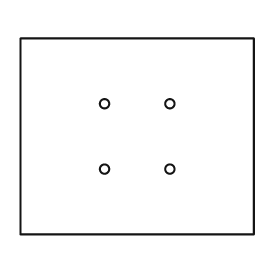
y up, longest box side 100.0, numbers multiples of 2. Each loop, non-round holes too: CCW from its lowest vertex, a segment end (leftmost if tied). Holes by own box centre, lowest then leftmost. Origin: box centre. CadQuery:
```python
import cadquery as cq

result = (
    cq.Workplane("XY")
    .moveTo(-50.0, -42.0)
    .lineTo(50.0, -42.0)
    .lineTo(50.0, 42.0)
    .lineTo(-50.0, 42.0)
    .close()
    .moveTo(-14.0, -14.0)
    .circle(2.0)
    .moveTo(14.0, -14.0)
    .circle(2.0)
    .moveTo(-14.0, 14.0)
    .circle(2.0)
    .moveTo(14.0, 14.0)
    .circle(2.0)
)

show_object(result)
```